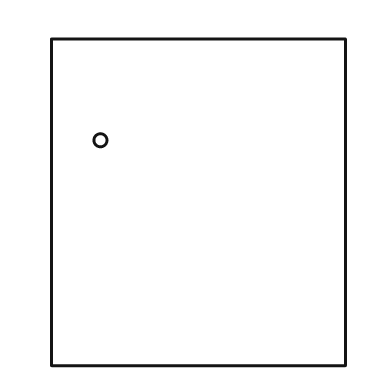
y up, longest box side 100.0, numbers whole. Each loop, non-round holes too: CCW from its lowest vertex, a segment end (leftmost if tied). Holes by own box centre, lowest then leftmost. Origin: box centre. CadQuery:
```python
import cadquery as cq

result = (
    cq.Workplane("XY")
    .moveTo(-45.0, -50.0)
    .lineTo(45.0, -50.0)
    .lineTo(45.0, 50.0)
    .lineTo(-45.0, 50.0)
    .close()
    .moveTo(-30.0, 19.0)
    .circle(2.0)
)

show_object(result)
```